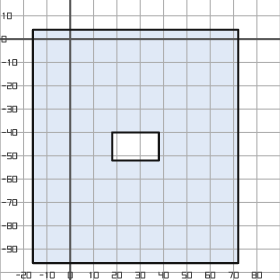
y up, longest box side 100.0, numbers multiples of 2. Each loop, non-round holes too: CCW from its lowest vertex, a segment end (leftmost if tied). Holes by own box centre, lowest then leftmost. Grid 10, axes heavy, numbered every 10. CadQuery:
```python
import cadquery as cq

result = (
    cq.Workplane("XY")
    .moveTo(-16.0, -96.0)
    .lineTo(72.0, -96.0)
    .lineTo(72.0, 4.0)
    .lineTo(-16.0, 4.0)
    .close()
    .moveTo(18.0, -52.0)
    .lineTo(38.0, -52.0)
    .lineTo(38.0, -40.0)
    .lineTo(18.0, -40.0)
    .close()
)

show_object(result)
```